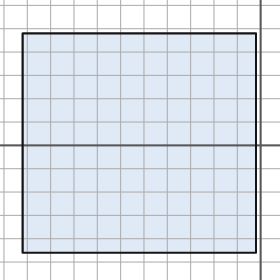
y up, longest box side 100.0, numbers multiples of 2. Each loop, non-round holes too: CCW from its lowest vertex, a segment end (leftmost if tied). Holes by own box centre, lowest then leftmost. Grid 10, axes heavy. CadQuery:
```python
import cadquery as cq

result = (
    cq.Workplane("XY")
    .moveTo(-102.0, -46.0)
    .lineTo(-2.0, -46.0)
    .lineTo(-2.0, 48.0)
    .lineTo(-102.0, 48.0)
    .close()
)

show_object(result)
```